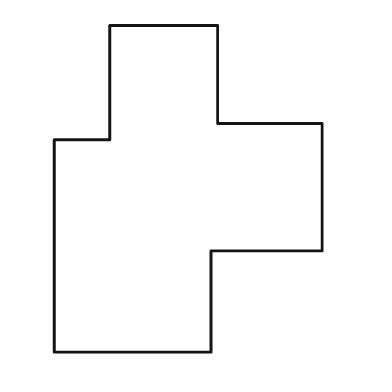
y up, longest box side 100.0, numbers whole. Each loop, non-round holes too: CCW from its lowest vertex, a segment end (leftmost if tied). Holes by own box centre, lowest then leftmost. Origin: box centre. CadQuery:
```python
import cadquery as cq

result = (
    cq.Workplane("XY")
    .moveTo(-41.0, -50.0)
    .lineTo(7.0, -50.0)
    .lineTo(7.0, -19.0)
    .lineTo(41.0, -19.0)
    .lineTo(41.0, 20.0)
    .lineTo(9.0, 20.0)
    .lineTo(9.0, 50.0)
    .lineTo(-24.0, 50.0)
    .lineTo(-24.0, 15.0)
    .lineTo(-41.0, 15.0)
    .close()
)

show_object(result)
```